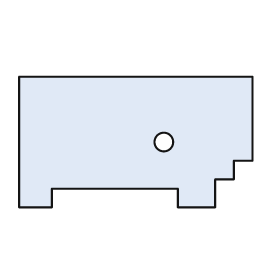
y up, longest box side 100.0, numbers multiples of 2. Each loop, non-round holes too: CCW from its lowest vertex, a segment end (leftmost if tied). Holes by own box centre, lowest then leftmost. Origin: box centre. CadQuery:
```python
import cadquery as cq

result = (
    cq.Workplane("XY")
    .moveTo(-50.0, -28.0)
    .lineTo(-36.0, -28.0)
    .lineTo(-36.0, -20.0)
    .lineTo(18.0, -20.0)
    .lineTo(18.0, -28.0)
    .lineTo(34.0, -28.0)
    .lineTo(34.0, -16.0)
    .lineTo(42.0, -16.0)
    .lineTo(42.0, -8.0)
    .lineTo(50.0, -8.0)
    .lineTo(50.0, 28.0)
    .lineTo(-50.0, 28.0)
    .close()
    .moveTo(12.0, 0.0)
    .circle(4.0)
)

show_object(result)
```